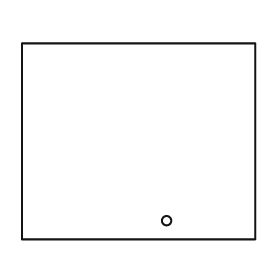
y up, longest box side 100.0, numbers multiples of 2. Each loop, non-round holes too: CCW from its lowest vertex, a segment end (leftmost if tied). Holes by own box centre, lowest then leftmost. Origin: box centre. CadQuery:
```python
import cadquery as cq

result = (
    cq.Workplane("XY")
    .moveTo(-50.0, -42.0)
    .lineTo(50.0, -42.0)
    .lineTo(50.0, 42.0)
    .lineTo(-50.0, 42.0)
    .close()
    .moveTo(12.0, -34.0)
    .circle(2.0)
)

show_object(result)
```